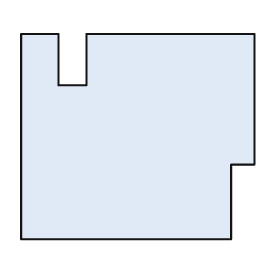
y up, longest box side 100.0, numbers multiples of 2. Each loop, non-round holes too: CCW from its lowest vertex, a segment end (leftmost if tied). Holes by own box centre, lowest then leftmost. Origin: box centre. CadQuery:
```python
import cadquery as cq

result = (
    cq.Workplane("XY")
    .moveTo(-50.0, -44.0)
    .lineTo(40.0, -44.0)
    .lineTo(40.0, -12.0)
    .lineTo(50.0, -12.0)
    .lineTo(50.0, 44.0)
    .lineTo(-22.0, 44.0)
    .lineTo(-22.0, 22.0)
    .lineTo(-34.0, 22.0)
    .lineTo(-34.0, 44.0)
    .lineTo(-50.0, 44.0)
    .close()
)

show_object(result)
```